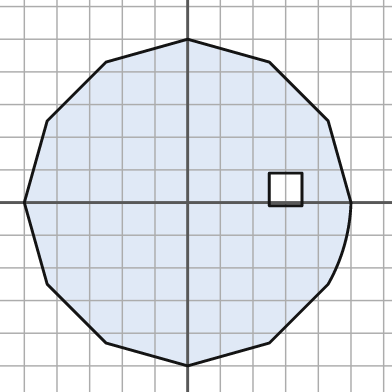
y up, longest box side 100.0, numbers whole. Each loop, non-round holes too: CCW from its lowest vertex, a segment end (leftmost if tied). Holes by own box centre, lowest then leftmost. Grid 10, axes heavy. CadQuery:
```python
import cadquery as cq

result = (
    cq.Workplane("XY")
    .moveTo(0.0, -50.0)
    .lineTo(25.0, -43.0)
    .lineTo(43.0, -25.0)
    .threePointArc((48.0, -13.0), (50.0, 0.0))
    .lineTo(43.0, 25.0)
    .lineTo(25.0, 43.0)
    .lineTo(0.0, 50.0)
    .lineTo(-25.0, 43.0)
    .lineTo(-43.0, 25.0)
    .lineTo(-50.0, 0.0)
    .lineTo(-43.0, -25.0)
    .lineTo(-25.0, -43.0)
    .close()
    .moveTo(25.0, -1.0)
    .lineTo(35.0, -1.0)
    .lineTo(35.0, 9.0)
    .lineTo(25.0, 9.0)
    .close()
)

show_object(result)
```